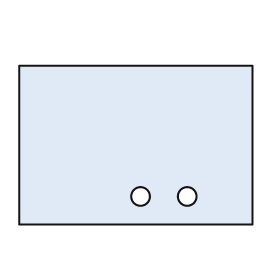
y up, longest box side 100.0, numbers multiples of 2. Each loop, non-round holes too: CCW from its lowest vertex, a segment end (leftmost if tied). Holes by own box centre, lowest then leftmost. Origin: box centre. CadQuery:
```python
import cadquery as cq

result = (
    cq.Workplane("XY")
    .moveTo(-50.0, -34.0)
    .lineTo(50.0, -34.0)
    .lineTo(50.0, 34.0)
    .lineTo(-50.0, 34.0)
    .close()
    .moveTo(2.0, -22.0)
    .circle(4.0)
    .moveTo(22.0, -22.0)
    .circle(4.0)
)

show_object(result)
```